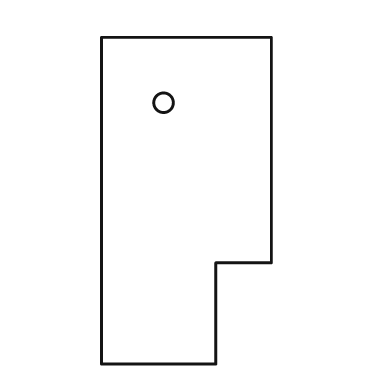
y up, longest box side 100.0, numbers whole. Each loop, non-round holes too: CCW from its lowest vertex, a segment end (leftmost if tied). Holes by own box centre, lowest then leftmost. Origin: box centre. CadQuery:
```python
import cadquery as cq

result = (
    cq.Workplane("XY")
    .moveTo(-26.0, -50.0)
    .lineTo(9.0, -50.0)
    .lineTo(9.0, -19.0)
    .lineTo(26.0, -19.0)
    .lineTo(26.0, 50.0)
    .lineTo(-26.0, 50.0)
    .close()
    .moveTo(-7.0, 30.0)
    .circle(3.0)
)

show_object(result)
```